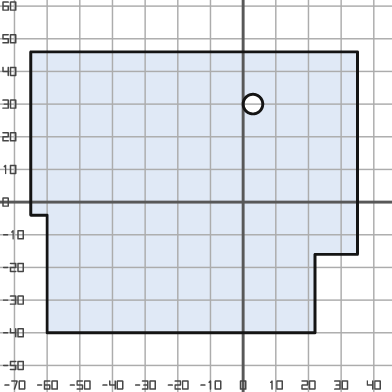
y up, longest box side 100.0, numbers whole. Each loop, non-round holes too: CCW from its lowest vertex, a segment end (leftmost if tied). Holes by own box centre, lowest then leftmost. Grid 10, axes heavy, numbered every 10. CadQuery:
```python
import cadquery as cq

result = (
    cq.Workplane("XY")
    .moveTo(-60.0, -40.0)
    .lineTo(22.0, -40.0)
    .lineTo(22.0, -16.0)
    .lineTo(35.0, -16.0)
    .lineTo(35.0, 46.0)
    .lineTo(-65.0, 46.0)
    .lineTo(-65.0, -4.0)
    .lineTo(-60.0, -4.0)
    .close()
    .moveTo(3.0, 30.0)
    .circle(3.0)
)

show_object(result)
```